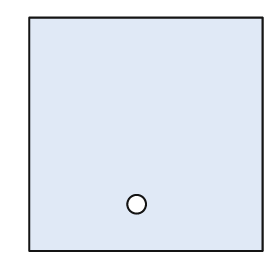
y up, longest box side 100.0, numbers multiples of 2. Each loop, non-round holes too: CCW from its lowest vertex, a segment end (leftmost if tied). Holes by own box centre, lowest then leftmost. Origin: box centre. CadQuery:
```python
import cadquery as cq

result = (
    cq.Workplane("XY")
    .moveTo(-50.0, -50.0)
    .lineTo(50.0, -50.0)
    .lineTo(50.0, 50.0)
    .lineTo(-50.0, 50.0)
    .close()
    .moveTo(-4.0, -30.0)
    .circle(4.0)
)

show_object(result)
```